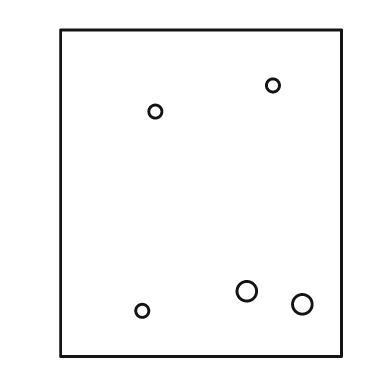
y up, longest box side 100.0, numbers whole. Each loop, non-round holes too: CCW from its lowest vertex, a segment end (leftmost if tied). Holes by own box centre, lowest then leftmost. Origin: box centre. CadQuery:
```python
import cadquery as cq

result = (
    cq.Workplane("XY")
    .moveTo(-43.0, -50.0)
    .lineTo(43.0, -50.0)
    .lineTo(43.0, 50.0)
    .lineTo(-43.0, 50.0)
    .close()
    .moveTo(-18.0, -36.0)
    .circle(2.0)
    .moveTo(31.0, -34.0)
    .circle(3.0)
    .moveTo(14.0, -30.0)
    .circle(3.0)
    .moveTo(-14.0, 25.0)
    .circle(2.0)
    .moveTo(22.0, 33.0)
    .circle(2.0)
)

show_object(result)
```